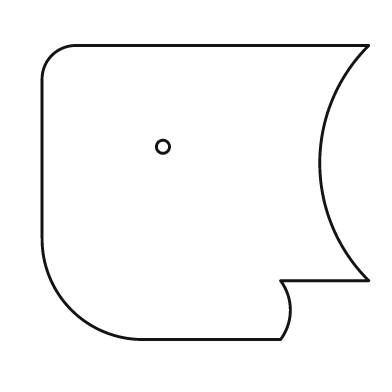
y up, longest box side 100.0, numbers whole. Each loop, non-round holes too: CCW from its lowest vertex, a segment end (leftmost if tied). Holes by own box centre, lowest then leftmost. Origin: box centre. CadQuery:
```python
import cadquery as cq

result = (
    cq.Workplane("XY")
    .moveTo(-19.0, -45.0)
    .lineTo(23.0, -45.0)
    .threePointArc((26.0, -36.0), (23.0, -27.0))
    .lineTo(50.0, -27.0)
    .threePointArc((35.0, 9.0), (50.0, 45.0))
    .lineTo(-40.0, 45.0)
    .threePointArc((-47.0, 42.0), (-50.0, 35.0))
    .lineTo(-50.0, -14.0)
    .threePointArc((-41.0, -36.0), (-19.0, -45.0))
    .close()
    .moveTo(-13.0, 14.0)
    .circle(2.0)
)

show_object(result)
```